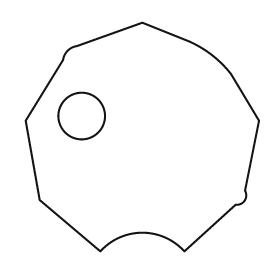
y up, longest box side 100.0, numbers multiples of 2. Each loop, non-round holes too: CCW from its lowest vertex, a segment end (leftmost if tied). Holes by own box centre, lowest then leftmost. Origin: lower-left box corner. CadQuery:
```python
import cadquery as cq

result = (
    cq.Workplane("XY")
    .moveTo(32.0, 0.0)
    .threePointArc((50.0, 8.0), (68.0, 0.0))
    .lineTo(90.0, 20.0)
    .threePointArc((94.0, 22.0), (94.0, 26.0))
    .lineTo(100.0, 56.0)
    .lineTo(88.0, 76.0)
    .threePointArc((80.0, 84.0), (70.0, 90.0))
    .lineTo(50.0, 98.0)
    .lineTo(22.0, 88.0)
    .threePointArc((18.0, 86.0), (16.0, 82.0))
    .lineTo(0.0, 56.0)
    .lineTo(6.0, 22.0)
    .close()
    .moveTo(24.0, 58.0)
    .circle(10.0)
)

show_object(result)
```